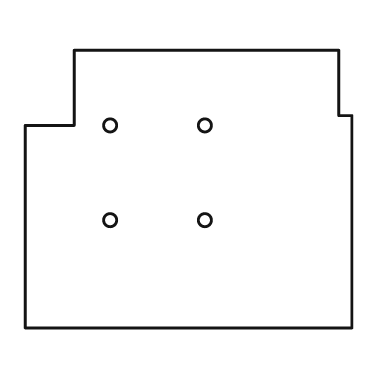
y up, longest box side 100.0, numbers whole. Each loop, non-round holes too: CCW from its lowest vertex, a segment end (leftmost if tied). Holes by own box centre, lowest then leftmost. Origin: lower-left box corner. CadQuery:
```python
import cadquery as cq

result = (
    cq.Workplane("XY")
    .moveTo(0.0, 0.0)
    .lineTo(100.0, 0.0)
    .lineTo(100.0, 65.0)
    .lineTo(96.0, 65.0)
    .lineTo(96.0, 85.0)
    .lineTo(15.0, 85.0)
    .lineTo(15.0, 62.0)
    .lineTo(0.0, 62.0)
    .close()
    .moveTo(26.0, 33.0)
    .circle(2.0)
    .moveTo(55.0, 33.0)
    .circle(2.0)
    .moveTo(26.0, 62.0)
    .circle(2.0)
    .moveTo(55.0, 62.0)
    .circle(2.0)
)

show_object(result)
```